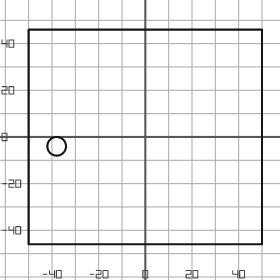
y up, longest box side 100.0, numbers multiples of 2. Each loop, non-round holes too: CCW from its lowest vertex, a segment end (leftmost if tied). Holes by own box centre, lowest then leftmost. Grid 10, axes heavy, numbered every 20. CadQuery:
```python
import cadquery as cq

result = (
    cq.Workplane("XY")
    .moveTo(-50.0, -46.0)
    .lineTo(50.0, -46.0)
    .lineTo(50.0, 46.0)
    .lineTo(-50.0, 46.0)
    .close()
    .moveTo(-38.0, -4.0)
    .circle(4.0)
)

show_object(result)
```